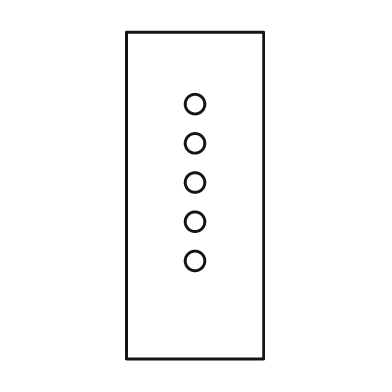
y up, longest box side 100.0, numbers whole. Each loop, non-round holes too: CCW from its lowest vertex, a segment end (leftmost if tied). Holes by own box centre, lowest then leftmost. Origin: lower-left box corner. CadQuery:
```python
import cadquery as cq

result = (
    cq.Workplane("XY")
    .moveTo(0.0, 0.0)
    .lineTo(42.0, 0.0)
    .lineTo(42.0, 100.0)
    .lineTo(0.0, 100.0)
    .close()
    .moveTo(21.0, 30.0)
    .circle(3.0)
    .moveTo(21.0, 42.0)
    .circle(3.0)
    .moveTo(21.0, 54.0)
    .circle(3.0)
    .moveTo(21.0, 66.0)
    .circle(3.0)
    .moveTo(21.0, 78.0)
    .circle(3.0)
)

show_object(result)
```